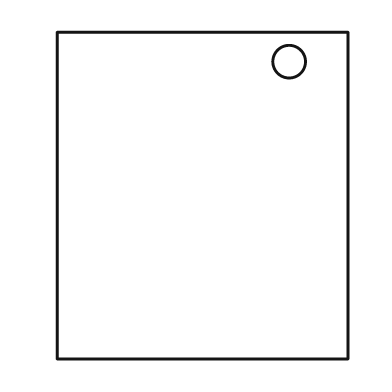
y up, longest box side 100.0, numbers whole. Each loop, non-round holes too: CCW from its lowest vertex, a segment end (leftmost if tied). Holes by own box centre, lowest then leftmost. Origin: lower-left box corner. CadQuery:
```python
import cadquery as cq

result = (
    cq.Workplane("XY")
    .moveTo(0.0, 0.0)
    .lineTo(89.0, 0.0)
    .lineTo(89.0, 100.0)
    .lineTo(0.0, 100.0)
    .close()
    .moveTo(71.0, 91.0)
    .circle(5.0)
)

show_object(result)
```